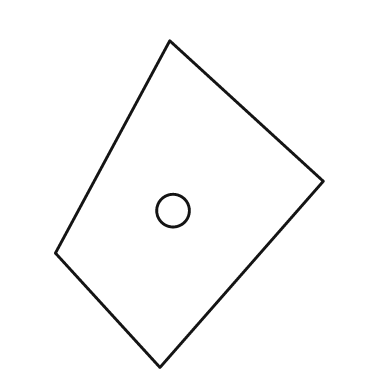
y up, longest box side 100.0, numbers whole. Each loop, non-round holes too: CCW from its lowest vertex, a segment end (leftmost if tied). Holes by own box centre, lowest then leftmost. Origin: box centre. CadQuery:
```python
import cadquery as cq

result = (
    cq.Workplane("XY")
    .moveTo(-9.0, -50.0)
    .lineTo(41.0, 7.0)
    .lineTo(-6.0, 50.0)
    .lineTo(-41.0, -15.0)
    .close()
    .moveTo(-5.0, -2.0)
    .circle(5.0)
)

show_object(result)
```